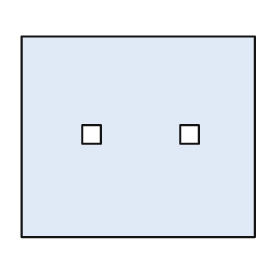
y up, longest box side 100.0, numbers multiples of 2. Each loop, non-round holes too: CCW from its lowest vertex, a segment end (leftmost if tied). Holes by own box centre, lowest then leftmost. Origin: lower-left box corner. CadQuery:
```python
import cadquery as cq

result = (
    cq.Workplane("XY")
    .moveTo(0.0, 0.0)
    .lineTo(100.0, 0.0)
    .lineTo(100.0, 86.0)
    .lineTo(0.0, 86.0)
    .close()
    .moveTo(26.0, 40.0)
    .lineTo(34.0, 40.0)
    .lineTo(34.0, 48.0)
    .lineTo(26.0, 48.0)
    .close()
    .moveTo(68.0, 40.0)
    .lineTo(76.0, 40.0)
    .lineTo(76.0, 48.0)
    .lineTo(68.0, 48.0)
    .close()
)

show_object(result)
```